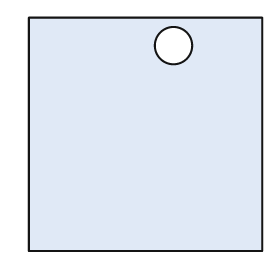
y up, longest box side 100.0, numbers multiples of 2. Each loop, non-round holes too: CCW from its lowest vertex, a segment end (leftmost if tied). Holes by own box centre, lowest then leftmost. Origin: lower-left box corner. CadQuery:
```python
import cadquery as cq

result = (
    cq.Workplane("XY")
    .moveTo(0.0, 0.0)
    .lineTo(100.0, 0.0)
    .lineTo(100.0, 100.0)
    .lineTo(0.0, 100.0)
    .close()
    .moveTo(62.0, 88.0)
    .circle(8.0)
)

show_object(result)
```